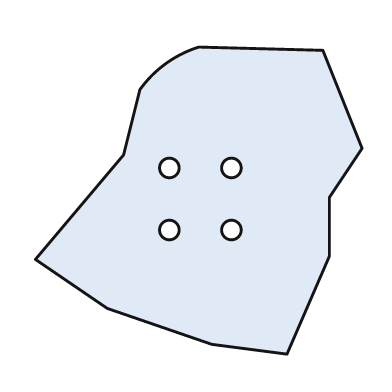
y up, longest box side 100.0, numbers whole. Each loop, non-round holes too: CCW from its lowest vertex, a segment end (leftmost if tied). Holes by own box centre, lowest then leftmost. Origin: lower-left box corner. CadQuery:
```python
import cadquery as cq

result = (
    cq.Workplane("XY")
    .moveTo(77.0, 0.0)
    .lineTo(90.0, 30.0)
    .lineTo(90.0, 48.0)
    .lineTo(100.0, 63.0)
    .lineTo(88.0, 93.0)
    .lineTo(50.0, 94.0)
    .threePointArc((40.0, 89.0), (32.0, 81.0))
    .lineTo(27.0, 61.0)
    .lineTo(0.0, 29.0)
    .lineTo(22.0, 14.0)
    .lineTo(54.0, 3.0)
    .close()
    .moveTo(41.0, 38.0)
    .circle(3.0)
    .moveTo(60.0, 38.0)
    .circle(3.0)
    .moveTo(41.0, 57.0)
    .circle(3.0)
    .moveTo(60.0, 57.0)
    .circle(3.0)
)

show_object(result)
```